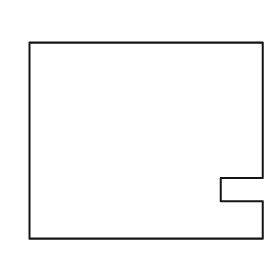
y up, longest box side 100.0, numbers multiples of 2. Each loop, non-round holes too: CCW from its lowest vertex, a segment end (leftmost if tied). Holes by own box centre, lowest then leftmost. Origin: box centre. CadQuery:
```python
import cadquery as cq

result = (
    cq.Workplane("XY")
    .moveTo(-50.0, -42.0)
    .lineTo(50.0, -42.0)
    .lineTo(50.0, -26.0)
    .lineTo(32.0, -26.0)
    .lineTo(32.0, -16.0)
    .lineTo(50.0, -16.0)
    .lineTo(50.0, 42.0)
    .lineTo(-50.0, 42.0)
    .close()
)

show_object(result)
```